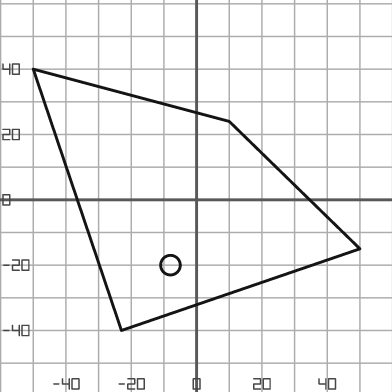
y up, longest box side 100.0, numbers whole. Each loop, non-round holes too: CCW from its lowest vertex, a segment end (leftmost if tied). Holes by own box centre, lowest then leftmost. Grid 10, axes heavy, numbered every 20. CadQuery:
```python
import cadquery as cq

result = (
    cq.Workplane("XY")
    .moveTo(-23.0, -40.0)
    .lineTo(50.0, -15.0)
    .lineTo(10.0, 24.0)
    .lineTo(-50.0, 40.0)
    .close()
    .moveTo(-8.0, -20.0)
    .circle(3.0)
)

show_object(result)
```